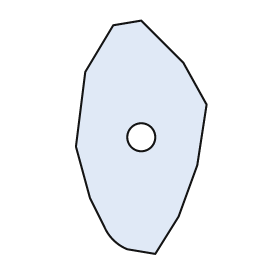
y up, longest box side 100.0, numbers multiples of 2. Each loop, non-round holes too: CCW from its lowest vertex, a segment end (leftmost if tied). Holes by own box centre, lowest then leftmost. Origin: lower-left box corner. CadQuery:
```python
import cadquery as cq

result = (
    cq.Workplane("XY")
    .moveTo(34.0, 0.0)
    .lineTo(44.0, 16.0)
    .lineTo(52.0, 38.0)
    .lineTo(56.0, 64.0)
    .lineTo(46.0, 82.0)
    .lineTo(28.0, 100.0)
    .lineTo(16.0, 98.0)
    .lineTo(4.0, 78.0)
    .lineTo(0.0, 46.0)
    .lineTo(6.0, 24.0)
    .lineTo(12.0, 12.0)
    .threePointArc((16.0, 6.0), (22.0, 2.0))
    .close()
    .moveTo(28.0, 50.0)
    .circle(6.0)
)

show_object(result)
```